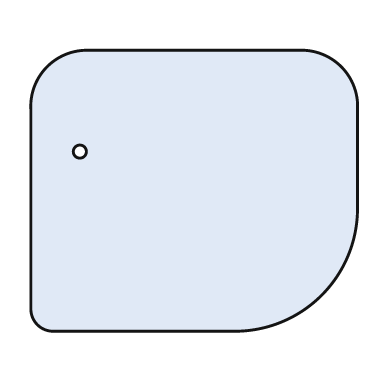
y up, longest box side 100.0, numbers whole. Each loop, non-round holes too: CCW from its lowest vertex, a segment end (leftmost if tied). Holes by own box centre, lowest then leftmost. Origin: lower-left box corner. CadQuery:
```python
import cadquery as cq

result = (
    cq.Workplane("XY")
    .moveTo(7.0, 0.0)
    .lineTo(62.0, 0.0)
    .threePointArc((89.0, 11.0), (100.0, 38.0))
    .lineTo(100.0, 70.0)
    .threePointArc((95.0, 81.0), (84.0, 86.0))
    .lineTo(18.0, 86.0)
    .threePointArc((5.0, 81.0), (0.0, 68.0))
    .lineTo(0.0, 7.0)
    .threePointArc((2.0, 2.0), (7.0, 0.0))
    .close()
    .moveTo(15.0, 55.0)
    .circle(2.0)
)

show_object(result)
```